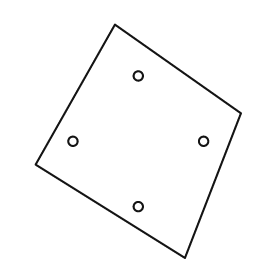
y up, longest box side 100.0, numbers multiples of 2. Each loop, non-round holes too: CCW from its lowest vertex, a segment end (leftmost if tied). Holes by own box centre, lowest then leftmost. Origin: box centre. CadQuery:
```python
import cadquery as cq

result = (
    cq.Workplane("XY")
    .moveTo(20.0, -50.0)
    .lineTo(44.0, 12.0)
    .lineTo(-10.0, 50.0)
    .lineTo(-44.0, -10.0)
    .close()
    .moveTo(0.0, -28.0)
    .circle(2.0)
    .moveTo(-28.0, 0.0)
    .circle(2.0)
    .moveTo(28.0, 0.0)
    .circle(2.0)
    .moveTo(0.0, 28.0)
    .circle(2.0)
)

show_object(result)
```